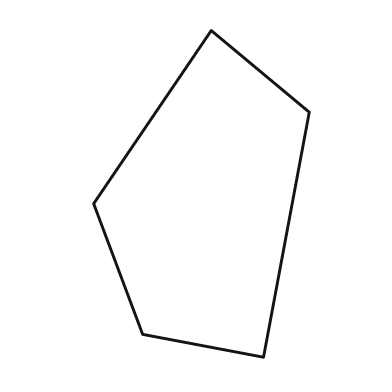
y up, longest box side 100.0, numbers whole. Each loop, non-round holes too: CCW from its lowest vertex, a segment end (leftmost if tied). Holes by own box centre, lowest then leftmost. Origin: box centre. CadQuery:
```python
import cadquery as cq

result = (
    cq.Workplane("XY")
    .moveTo(19.0, -50.0)
    .lineTo(33.0, 25.0)
    .lineTo(3.0, 50.0)
    .lineTo(-33.0, -3.0)
    .lineTo(-18.0, -43.0)
    .close()
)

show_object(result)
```